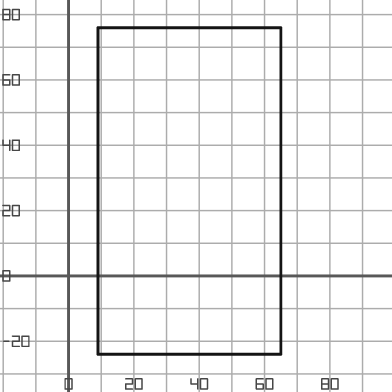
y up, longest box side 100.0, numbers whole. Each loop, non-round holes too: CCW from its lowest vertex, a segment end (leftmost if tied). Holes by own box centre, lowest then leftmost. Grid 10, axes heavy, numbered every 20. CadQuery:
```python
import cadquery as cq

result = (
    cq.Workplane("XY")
    .moveTo(9.0, -24.0)
    .lineTo(65.0, -24.0)
    .lineTo(65.0, 76.0)
    .lineTo(9.0, 76.0)
    .close()
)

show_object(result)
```